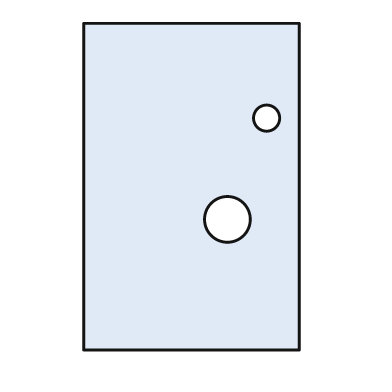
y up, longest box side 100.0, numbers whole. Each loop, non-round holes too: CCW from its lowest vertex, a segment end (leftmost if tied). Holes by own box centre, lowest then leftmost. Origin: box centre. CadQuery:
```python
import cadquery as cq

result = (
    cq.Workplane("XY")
    .moveTo(-33.0, -50.0)
    .lineTo(33.0, -50.0)
    .lineTo(33.0, 50.0)
    .lineTo(-33.0, 50.0)
    .close()
    .moveTo(11.0, -10.0)
    .circle(7.0)
    .moveTo(23.0, 21.0)
    .circle(4.0)
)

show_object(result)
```